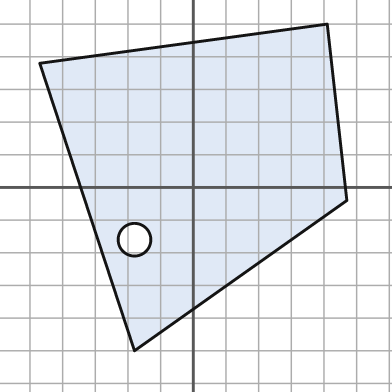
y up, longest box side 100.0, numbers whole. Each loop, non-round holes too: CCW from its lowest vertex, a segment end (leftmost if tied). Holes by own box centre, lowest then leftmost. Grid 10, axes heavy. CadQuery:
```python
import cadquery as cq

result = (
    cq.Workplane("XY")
    .moveTo(-18.0, -50.0)
    .lineTo(47.0, -4.0)
    .lineTo(41.0, 50.0)
    .lineTo(-47.0, 38.0)
    .close()
    .moveTo(-18.0, -16.0)
    .circle(5.0)
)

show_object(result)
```